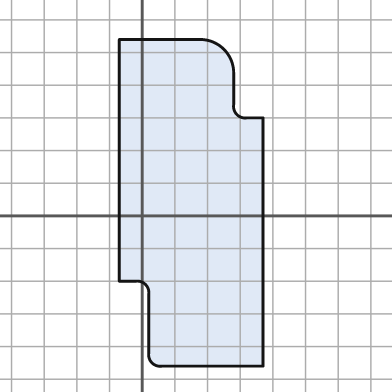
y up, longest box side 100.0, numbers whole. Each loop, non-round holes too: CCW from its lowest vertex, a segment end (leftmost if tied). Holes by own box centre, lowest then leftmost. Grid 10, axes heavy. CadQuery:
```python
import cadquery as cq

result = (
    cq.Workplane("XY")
    .moveTo(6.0, -46.0)
    .lineTo(37.0, -46.0)
    .lineTo(37.0, 30.0)
    .lineTo(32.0, 30.0)
    .threePointArc((29.0, 31.0), (28.0, 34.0))
    .lineTo(28.0, 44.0)
    .threePointArc((25.0, 51.0), (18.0, 54.0))
    .lineTo(-7.0, 54.0)
    .lineTo(-7.0, -20.0)
    .lineTo(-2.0, -20.0)
    .threePointArc((1.0, -21.0), (2.0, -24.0))
    .lineTo(2.0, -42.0)
    .threePointArc((3.0, -45.0), (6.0, -46.0))
    .close()
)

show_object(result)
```